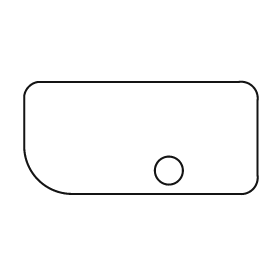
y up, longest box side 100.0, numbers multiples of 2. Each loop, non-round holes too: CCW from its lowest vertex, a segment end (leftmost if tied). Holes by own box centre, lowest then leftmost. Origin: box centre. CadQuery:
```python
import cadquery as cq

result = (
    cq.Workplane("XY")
    .moveTo(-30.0, -24.0)
    .lineTo(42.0, -24.0)
    .threePointArc((48.0, -22.0), (50.0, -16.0))
    .lineTo(50.0, 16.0)
    .threePointArc((48.0, 22.0), (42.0, 24.0))
    .lineTo(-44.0, 24.0)
    .threePointArc((-48.0, 22.0), (-50.0, 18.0))
    .lineTo(-50.0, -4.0)
    .threePointArc((-44.0, -18.0), (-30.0, -24.0))
    .close()
    .moveTo(12.0, -14.0)
    .circle(6.0)
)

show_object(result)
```